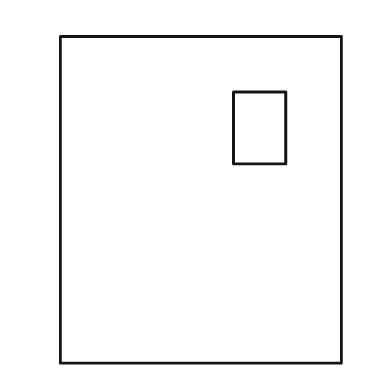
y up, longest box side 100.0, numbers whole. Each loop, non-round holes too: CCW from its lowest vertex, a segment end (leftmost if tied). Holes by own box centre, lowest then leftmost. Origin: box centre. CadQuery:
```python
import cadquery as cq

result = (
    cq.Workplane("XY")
    .moveTo(-43.0, -50.0)
    .lineTo(43.0, -50.0)
    .lineTo(43.0, 50.0)
    .lineTo(-43.0, 50.0)
    .close()
    .moveTo(10.0, 11.0)
    .lineTo(26.0, 11.0)
    .lineTo(26.0, 33.0)
    .lineTo(10.0, 33.0)
    .close()
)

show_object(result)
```